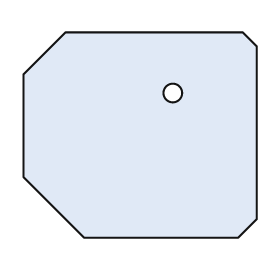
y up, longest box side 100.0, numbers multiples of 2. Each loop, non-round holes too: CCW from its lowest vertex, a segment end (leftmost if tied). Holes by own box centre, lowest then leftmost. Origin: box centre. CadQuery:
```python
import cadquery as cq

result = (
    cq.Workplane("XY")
    .moveTo(-24.0, -44.0)
    .lineTo(42.0, -44.0)
    .lineTo(50.0, -36.0)
    .lineTo(50.0, 38.0)
    .lineTo(44.0, 44.0)
    .lineTo(-32.0, 44.0)
    .lineTo(-50.0, 26.0)
    .lineTo(-50.0, -18.0)
    .close()
    .moveTo(14.0, 18.0)
    .circle(4.0)
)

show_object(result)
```